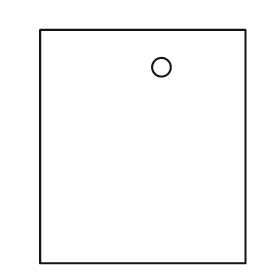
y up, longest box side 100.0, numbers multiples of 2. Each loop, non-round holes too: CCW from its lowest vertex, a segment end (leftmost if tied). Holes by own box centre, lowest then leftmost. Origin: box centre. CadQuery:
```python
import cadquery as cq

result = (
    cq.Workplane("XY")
    .moveTo(-44.0, -50.0)
    .lineTo(44.0, -50.0)
    .lineTo(44.0, 50.0)
    .lineTo(-44.0, 50.0)
    .close()
    .moveTo(8.0, 34.0)
    .circle(4.0)
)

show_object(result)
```